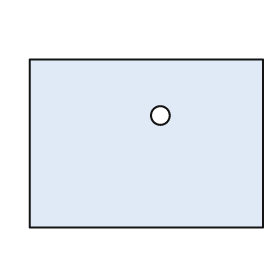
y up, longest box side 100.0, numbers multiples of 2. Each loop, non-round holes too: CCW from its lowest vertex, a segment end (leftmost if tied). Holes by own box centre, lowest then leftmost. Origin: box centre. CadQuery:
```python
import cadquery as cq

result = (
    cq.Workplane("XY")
    .moveTo(-50.0, -36.0)
    .lineTo(50.0, -36.0)
    .lineTo(50.0, 36.0)
    .lineTo(-50.0, 36.0)
    .close()
    .moveTo(6.0, 12.0)
    .circle(4.0)
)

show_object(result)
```